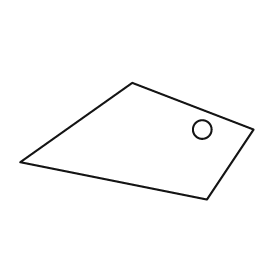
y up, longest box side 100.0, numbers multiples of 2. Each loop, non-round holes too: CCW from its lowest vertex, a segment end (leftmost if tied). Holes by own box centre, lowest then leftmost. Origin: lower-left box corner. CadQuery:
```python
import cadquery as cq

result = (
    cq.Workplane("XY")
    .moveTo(80.0, 0.0)
    .lineTo(100.0, 30.0)
    .lineTo(48.0, 50.0)
    .lineTo(0.0, 16.0)
    .close()
    .moveTo(78.0, 30.0)
    .circle(4.0)
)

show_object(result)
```